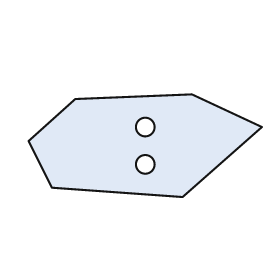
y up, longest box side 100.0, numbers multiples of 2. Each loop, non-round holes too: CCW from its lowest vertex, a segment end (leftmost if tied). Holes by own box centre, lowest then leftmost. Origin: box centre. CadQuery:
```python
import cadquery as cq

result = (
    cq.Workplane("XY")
    .moveTo(16.0, -22.0)
    .lineTo(50.0, 8.0)
    .lineTo(20.0, 22.0)
    .lineTo(-30.0, 20.0)
    .lineTo(-50.0, 2.0)
    .lineTo(-40.0, -18.0)
    .close()
    .moveTo(0.0, -8.0)
    .circle(4.0)
    .moveTo(0.0, 8.0)
    .circle(4.0)
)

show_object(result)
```